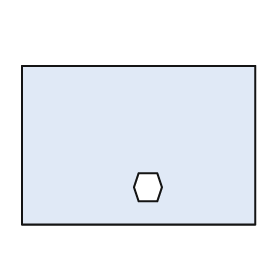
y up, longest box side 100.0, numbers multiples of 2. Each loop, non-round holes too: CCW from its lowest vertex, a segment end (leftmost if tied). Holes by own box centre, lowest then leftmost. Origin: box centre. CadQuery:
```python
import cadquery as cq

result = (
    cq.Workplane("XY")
    .moveTo(-50.0, -34.0)
    .lineTo(50.0, -34.0)
    .lineTo(50.0, 34.0)
    .lineTo(-50.0, 34.0)
    .close()
    .moveTo(0.0, -24.0)
    .lineTo(8.0, -24.0)
    .lineTo(10.0, -18.0)
    .lineTo(8.0, -12.0)
    .lineTo(0.0, -12.0)
    .lineTo(-2.0, -18.0)
    .close()
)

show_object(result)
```